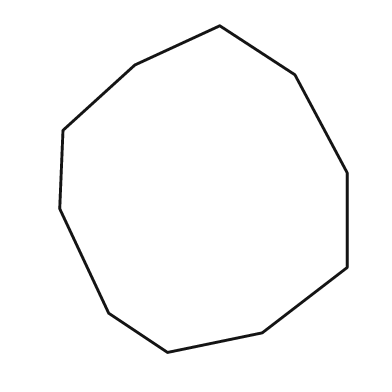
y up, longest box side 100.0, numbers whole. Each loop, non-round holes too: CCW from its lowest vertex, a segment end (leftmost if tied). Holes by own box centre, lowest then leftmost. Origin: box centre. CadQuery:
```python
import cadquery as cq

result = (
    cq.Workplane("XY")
    .moveTo(-11.0, -50.0)
    .lineTo(18.0, -44.0)
    .lineTo(44.0, -24.0)
    .lineTo(44.0, 5.0)
    .lineTo(28.0, 35.0)
    .lineTo(5.0, 50.0)
    .lineTo(-21.0, 38.0)
    .lineTo(-43.0, 18.0)
    .lineTo(-44.0, -6.0)
    .lineTo(-29.0, -38.0)
    .close()
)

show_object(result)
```